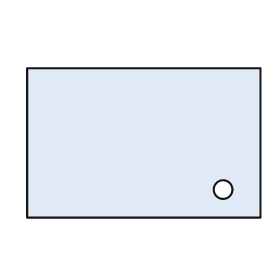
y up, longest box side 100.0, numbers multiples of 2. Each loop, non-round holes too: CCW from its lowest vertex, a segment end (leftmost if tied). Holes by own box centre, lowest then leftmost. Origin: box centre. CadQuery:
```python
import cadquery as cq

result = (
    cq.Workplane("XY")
    .moveTo(-50.0, -32.0)
    .lineTo(50.0, -32.0)
    .lineTo(50.0, 32.0)
    .lineTo(-50.0, 32.0)
    .close()
    .moveTo(34.0, -20.0)
    .circle(4.0)
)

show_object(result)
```